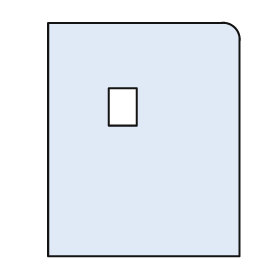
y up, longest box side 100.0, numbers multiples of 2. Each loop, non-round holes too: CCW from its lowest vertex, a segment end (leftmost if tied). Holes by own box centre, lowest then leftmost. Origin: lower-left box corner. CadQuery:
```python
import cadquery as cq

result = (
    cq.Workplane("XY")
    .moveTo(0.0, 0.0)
    .lineTo(82.0, 0.0)
    .lineTo(82.0, 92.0)
    .threePointArc((80.0, 98.0), (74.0, 100.0))
    .lineTo(0.0, 100.0)
    .close()
    .moveTo(26.0, 56.0)
    .lineTo(38.0, 56.0)
    .lineTo(38.0, 72.0)
    .lineTo(26.0, 72.0)
    .close()
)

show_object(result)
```